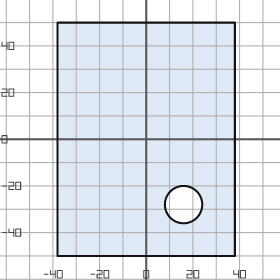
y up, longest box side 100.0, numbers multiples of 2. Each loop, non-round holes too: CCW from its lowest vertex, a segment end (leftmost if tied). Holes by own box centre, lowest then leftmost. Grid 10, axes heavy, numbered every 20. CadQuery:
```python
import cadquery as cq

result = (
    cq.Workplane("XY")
    .moveTo(-38.0, -50.0)
    .lineTo(38.0, -50.0)
    .lineTo(38.0, 50.0)
    .lineTo(-38.0, 50.0)
    .close()
    .moveTo(16.0, -28.0)
    .circle(8.0)
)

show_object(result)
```